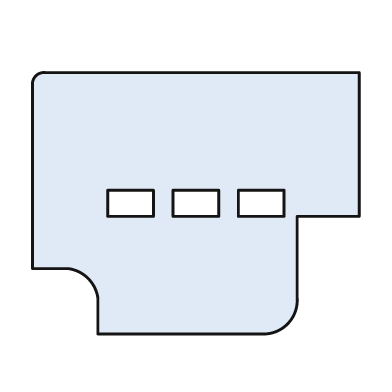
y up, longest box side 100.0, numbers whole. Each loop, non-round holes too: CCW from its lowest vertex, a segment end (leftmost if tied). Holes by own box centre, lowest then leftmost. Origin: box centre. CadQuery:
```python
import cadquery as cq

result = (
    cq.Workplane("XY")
    .moveTo(-30.0, -40.0)
    .lineTo(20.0, -40.0)
    .threePointArc((28.0, -37.0), (31.0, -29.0))
    .lineTo(31.0, -4.0)
    .lineTo(50.0, -4.0)
    .lineTo(50.0, 40.0)
    .lineTo(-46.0, 40.0)
    .threePointArc((-49.0, 39.0), (-50.0, 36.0))
    .lineTo(-50.0, -20.0)
    .lineTo(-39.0, -20.0)
    .threePointArc((-33.0, -23.0), (-30.0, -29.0))
    .close()
    .moveTo(-27.0, -4.0)
    .lineTo(-13.0, -4.0)
    .lineTo(-13.0, 4.0)
    .lineTo(-27.0, 4.0)
    .close()
    .moveTo(-7.0, -4.0)
    .lineTo(7.0, -4.0)
    .lineTo(7.0, 4.0)
    .lineTo(-7.0, 4.0)
    .close()
    .moveTo(13.0, -4.0)
    .lineTo(27.0, -4.0)
    .lineTo(27.0, 4.0)
    .lineTo(13.0, 4.0)
    .close()
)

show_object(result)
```